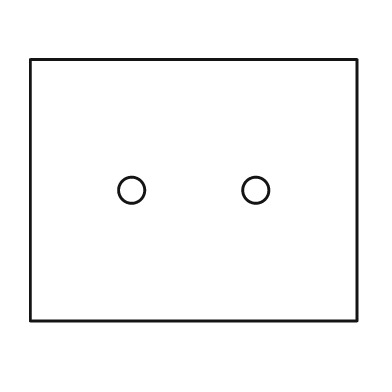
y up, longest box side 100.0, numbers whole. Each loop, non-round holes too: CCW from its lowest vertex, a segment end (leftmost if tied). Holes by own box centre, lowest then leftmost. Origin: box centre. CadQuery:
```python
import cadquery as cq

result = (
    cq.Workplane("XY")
    .moveTo(-50.0, -40.0)
    .lineTo(50.0, -40.0)
    .lineTo(50.0, 40.0)
    .lineTo(-50.0, 40.0)
    .close()
    .moveTo(-19.0, 0.0)
    .circle(4.0)
    .moveTo(19.0, 0.0)
    .circle(4.0)
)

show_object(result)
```